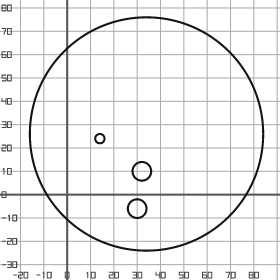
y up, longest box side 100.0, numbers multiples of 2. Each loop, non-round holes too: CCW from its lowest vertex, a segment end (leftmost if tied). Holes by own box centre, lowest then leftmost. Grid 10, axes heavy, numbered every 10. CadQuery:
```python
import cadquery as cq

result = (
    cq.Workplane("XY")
    .moveTo(34.0, 26.0)
    .circle(50.0)
    .moveTo(30.0, -6.0)
    .circle(4.0)
    .moveTo(32.0, 10.0)
    .circle(4.0)
    .moveTo(14.0, 24.0)
    .circle(2.0)
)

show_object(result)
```